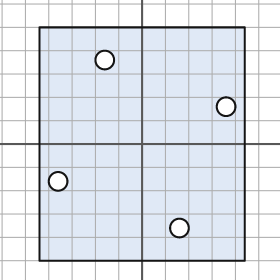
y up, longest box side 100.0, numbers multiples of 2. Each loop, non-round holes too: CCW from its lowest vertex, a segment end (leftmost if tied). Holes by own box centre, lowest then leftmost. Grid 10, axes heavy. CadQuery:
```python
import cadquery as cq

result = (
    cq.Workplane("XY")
    .moveTo(-44.0, -50.0)
    .lineTo(44.0, -50.0)
    .lineTo(44.0, 50.0)
    .lineTo(-44.0, 50.0)
    .close()
    .moveTo(16.0, -36.0)
    .circle(4.0)
    .moveTo(-36.0, -16.0)
    .circle(4.0)
    .moveTo(36.0, 16.0)
    .circle(4.0)
    .moveTo(-16.0, 36.0)
    .circle(4.0)
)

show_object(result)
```